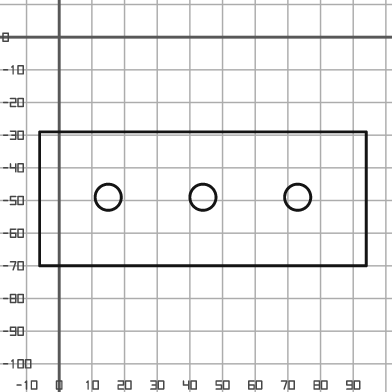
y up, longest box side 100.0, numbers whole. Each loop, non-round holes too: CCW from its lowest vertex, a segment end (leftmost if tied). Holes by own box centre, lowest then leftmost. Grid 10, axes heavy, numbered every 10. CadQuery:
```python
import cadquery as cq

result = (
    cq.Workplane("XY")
    .moveTo(-6.0, -70.0)
    .lineTo(94.0, -70.0)
    .lineTo(94.0, -29.0)
    .lineTo(-6.0, -29.0)
    .close()
    .moveTo(15.0, -49.0)
    .circle(4.0)
    .moveTo(44.0, -49.0)
    .circle(4.0)
    .moveTo(73.0, -49.0)
    .circle(4.0)
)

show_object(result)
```